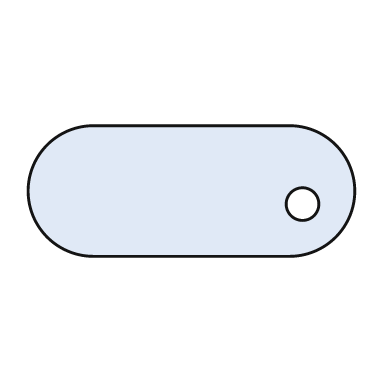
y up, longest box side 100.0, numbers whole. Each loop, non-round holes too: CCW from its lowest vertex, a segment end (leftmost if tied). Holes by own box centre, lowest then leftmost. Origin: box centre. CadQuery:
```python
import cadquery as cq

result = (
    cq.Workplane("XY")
    .moveTo(-30.0, -20.0)
    .lineTo(30.0, -20.0)
    .threePointArc((50.0, 0.0), (30.0, 20.0))
    .lineTo(-30.0, 20.0)
    .threePointArc((-50.0, 0.0), (-30.0, -20.0))
    .close()
    .moveTo(34.0, -4.0)
    .circle(5.0)
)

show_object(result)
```